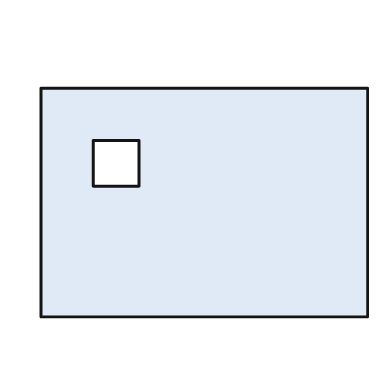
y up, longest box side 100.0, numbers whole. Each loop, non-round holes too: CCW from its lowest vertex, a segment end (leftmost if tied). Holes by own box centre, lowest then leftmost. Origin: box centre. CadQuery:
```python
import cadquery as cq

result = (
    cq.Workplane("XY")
    .moveTo(-50.0, -35.0)
    .lineTo(50.0, -35.0)
    .lineTo(50.0, 35.0)
    .lineTo(-50.0, 35.0)
    .close()
    .moveTo(-34.0, 5.0)
    .lineTo(-20.0, 5.0)
    .lineTo(-20.0, 19.0)
    .lineTo(-34.0, 19.0)
    .close()
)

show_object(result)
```